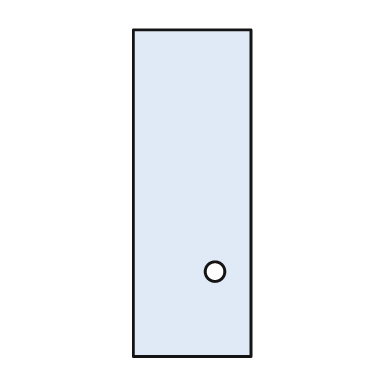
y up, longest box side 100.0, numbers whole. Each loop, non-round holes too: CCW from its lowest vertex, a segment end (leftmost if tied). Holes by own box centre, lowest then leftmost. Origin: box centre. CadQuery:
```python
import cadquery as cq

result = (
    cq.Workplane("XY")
    .moveTo(-18.0, -50.0)
    .lineTo(18.0, -50.0)
    .lineTo(18.0, 50.0)
    .lineTo(-18.0, 50.0)
    .close()
    .moveTo(7.0, -24.0)
    .circle(3.0)
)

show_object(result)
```